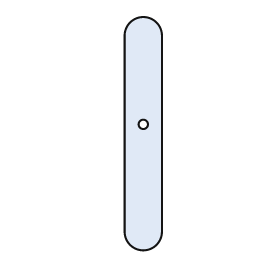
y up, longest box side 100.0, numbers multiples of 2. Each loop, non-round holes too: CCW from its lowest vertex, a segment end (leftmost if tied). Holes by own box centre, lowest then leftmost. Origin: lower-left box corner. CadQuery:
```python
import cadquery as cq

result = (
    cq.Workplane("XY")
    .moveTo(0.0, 8.0)
    .threePointArc((8.0, 0.0), (16.0, 8.0))
    .lineTo(16.0, 92.0)
    .threePointArc((8.0, 100.0), (0.0, 92.0))
    .close()
    .moveTo(8.0, 54.0)
    .circle(2.0)
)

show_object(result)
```